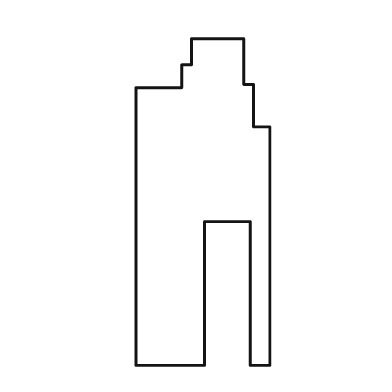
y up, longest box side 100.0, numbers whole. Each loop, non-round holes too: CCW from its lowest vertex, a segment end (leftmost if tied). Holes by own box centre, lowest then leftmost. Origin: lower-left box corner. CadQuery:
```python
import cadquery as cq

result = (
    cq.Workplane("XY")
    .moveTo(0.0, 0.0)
    .lineTo(21.0, 0.0)
    .lineTo(21.0, 44.0)
    .lineTo(35.0, 44.0)
    .lineTo(35.0, 0.0)
    .lineTo(41.0, 0.0)
    .lineTo(41.0, 73.0)
    .lineTo(36.0, 73.0)
    .lineTo(36.0, 86.0)
    .lineTo(33.0, 86.0)
    .lineTo(33.0, 100.0)
    .lineTo(17.0, 100.0)
    .lineTo(17.0, 92.0)
    .lineTo(14.0, 92.0)
    .lineTo(14.0, 85.0)
    .lineTo(0.0, 85.0)
    .close()
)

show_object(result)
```